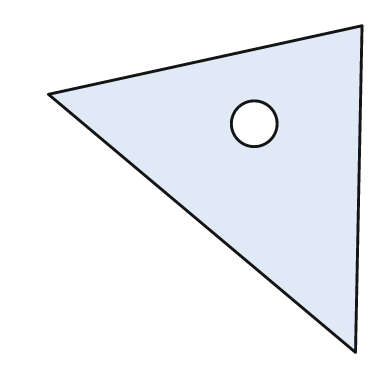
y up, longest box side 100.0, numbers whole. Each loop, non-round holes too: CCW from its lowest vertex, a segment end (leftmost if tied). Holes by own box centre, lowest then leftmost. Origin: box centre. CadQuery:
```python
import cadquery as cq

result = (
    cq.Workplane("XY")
    .moveTo(46.0, -50.0)
    .lineTo(48.0, 50.0)
    .lineTo(-48.0, 29.0)
    .close()
    .moveTo(15.0, 20.0)
    .circle(7.0)
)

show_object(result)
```